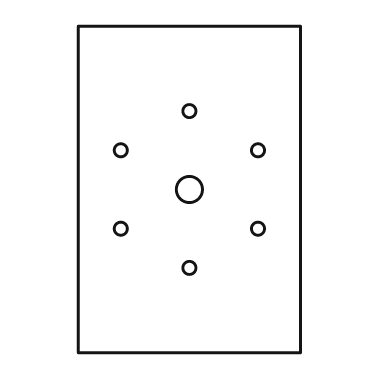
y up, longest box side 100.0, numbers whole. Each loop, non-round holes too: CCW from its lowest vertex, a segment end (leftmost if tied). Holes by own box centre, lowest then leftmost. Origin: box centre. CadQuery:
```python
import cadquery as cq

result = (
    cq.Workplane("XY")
    .moveTo(-34.0, -50.0)
    .lineTo(34.0, -50.0)
    .lineTo(34.0, 50.0)
    .lineTo(-34.0, 50.0)
    .close()
    .moveTo(0.0, -24.0)
    .circle(2.0)
    .moveTo(-21.0, -12.0)
    .circle(2.0)
    .moveTo(21.0, -12.0)
    .circle(2.0)
    .moveTo(0.0, 0.0)
    .circle(4.0)
    .moveTo(-21.0, 12.0)
    .circle(2.0)
    .moveTo(21.0, 12.0)
    .circle(2.0)
    .moveTo(0.0, 24.0)
    .circle(2.0)
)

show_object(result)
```